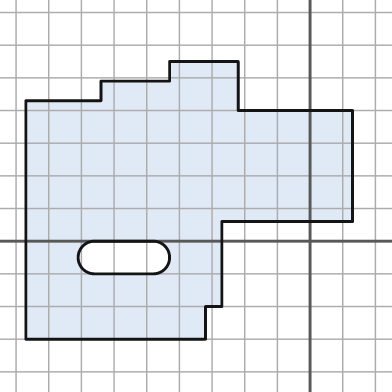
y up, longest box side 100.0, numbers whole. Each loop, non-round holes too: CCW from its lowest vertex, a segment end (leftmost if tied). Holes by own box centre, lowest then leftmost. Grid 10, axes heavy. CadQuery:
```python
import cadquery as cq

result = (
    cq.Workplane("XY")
    .moveTo(-87.0, -30.0)
    .lineTo(-32.0, -30.0)
    .lineTo(-32.0, -20.0)
    .lineTo(-27.0, -20.0)
    .lineTo(-27.0, 6.0)
    .lineTo(13.0, 6.0)
    .lineTo(13.0, 40.0)
    .lineTo(-22.0, 40.0)
    .lineTo(-22.0, 55.0)
    .lineTo(-43.0, 55.0)
    .lineTo(-43.0, 49.0)
    .lineTo(-64.0, 49.0)
    .lineTo(-64.0, 43.0)
    .lineTo(-87.0, 43.0)
    .close()
    .moveTo(-66.0, -10.0)
    .lineTo(-48.0, -10.0)
    .threePointArc((-43.0, -5.0), (-48.0, 0.0))
    .lineTo(-66.0, 0.0)
    .threePointArc((-71.0, -5.0), (-66.0, -10.0))
    .close()
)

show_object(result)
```